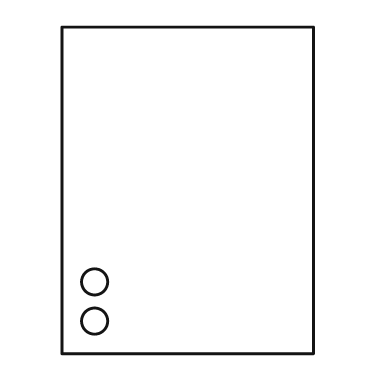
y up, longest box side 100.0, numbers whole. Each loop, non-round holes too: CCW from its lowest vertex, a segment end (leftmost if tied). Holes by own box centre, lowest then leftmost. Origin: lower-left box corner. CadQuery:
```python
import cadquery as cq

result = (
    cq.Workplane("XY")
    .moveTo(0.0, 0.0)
    .lineTo(77.0, 0.0)
    .lineTo(77.0, 100.0)
    .lineTo(0.0, 100.0)
    .close()
    .moveTo(10.0, 10.0)
    .circle(4.0)
    .moveTo(10.0, 22.0)
    .circle(4.0)
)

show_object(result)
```